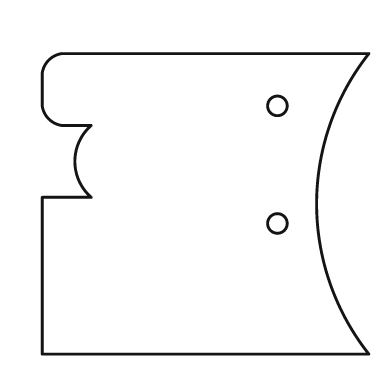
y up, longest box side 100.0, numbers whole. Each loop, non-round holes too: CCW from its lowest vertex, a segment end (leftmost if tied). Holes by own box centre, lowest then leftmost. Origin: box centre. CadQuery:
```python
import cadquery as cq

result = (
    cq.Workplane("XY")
    .moveTo(-50.0, -46.0)
    .lineTo(50.0, -46.0)
    .threePointArc((34.0, 0.0), (50.0, 46.0))
    .lineTo(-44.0, 46.0)
    .threePointArc((-48.0, 44.0), (-50.0, 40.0))
    .lineTo(-50.0, 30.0)
    .threePointArc((-48.0, 26.0), (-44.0, 24.0))
    .lineTo(-35.0, 24.0)
    .threePointArc((-40.0, 13.0), (-35.0, 2.0))
    .lineTo(-50.0, 2.0)
    .close()
    .moveTo(22.0, -6.0)
    .circle(3.0)
    .moveTo(22.0, 30.0)
    .circle(3.0)
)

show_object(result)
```